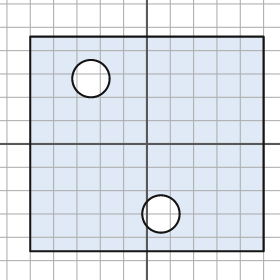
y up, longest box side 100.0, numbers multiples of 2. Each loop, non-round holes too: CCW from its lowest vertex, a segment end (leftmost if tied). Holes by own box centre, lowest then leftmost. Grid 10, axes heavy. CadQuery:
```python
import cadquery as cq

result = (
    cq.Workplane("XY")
    .moveTo(-50.0, -46.0)
    .lineTo(50.0, -46.0)
    .lineTo(50.0, 46.0)
    .lineTo(-50.0, 46.0)
    .close()
    .moveTo(6.0, -30.0)
    .circle(8.0)
    .moveTo(-24.0, 28.0)
    .circle(8.0)
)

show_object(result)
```